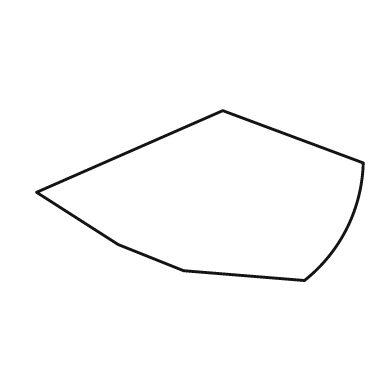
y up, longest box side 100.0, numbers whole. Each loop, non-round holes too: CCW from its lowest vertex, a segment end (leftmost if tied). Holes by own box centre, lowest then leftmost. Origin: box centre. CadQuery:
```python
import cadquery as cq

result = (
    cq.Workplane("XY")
    .moveTo(32.0, -26.0)
    .threePointArc((45.0, -10.0), (50.0, 10.0))
    .lineTo(7.0, 26.0)
    .lineTo(-50.0, 1.0)
    .lineTo(-25.0, -15.0)
    .lineTo(-5.0, -23.0)
    .close()
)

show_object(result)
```